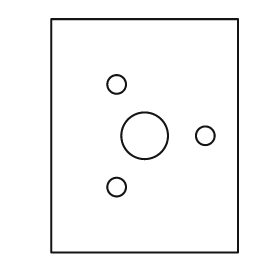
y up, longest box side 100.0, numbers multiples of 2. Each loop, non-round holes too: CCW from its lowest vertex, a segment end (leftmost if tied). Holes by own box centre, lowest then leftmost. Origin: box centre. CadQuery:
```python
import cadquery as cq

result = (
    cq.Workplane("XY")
    .moveTo(-40.0, -50.0)
    .lineTo(40.0, -50.0)
    .lineTo(40.0, 50.0)
    .lineTo(-40.0, 50.0)
    .close()
    .moveTo(-12.0, -22.0)
    .circle(4.0)
    .moveTo(0.0, 0.0)
    .circle(10.0)
    .moveTo(26.0, 0.0)
    .circle(4.0)
    .moveTo(-12.0, 22.0)
    .circle(4.0)
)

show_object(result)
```